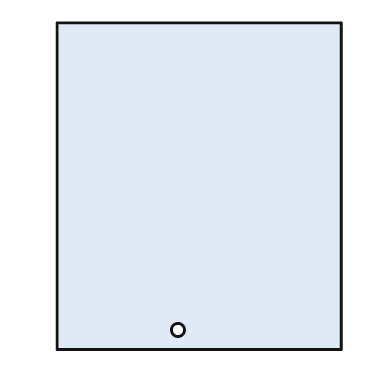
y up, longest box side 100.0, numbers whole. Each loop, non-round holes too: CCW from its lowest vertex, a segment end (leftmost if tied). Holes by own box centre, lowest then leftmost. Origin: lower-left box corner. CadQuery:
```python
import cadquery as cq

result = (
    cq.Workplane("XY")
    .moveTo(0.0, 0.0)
    .lineTo(87.0, 0.0)
    .lineTo(87.0, 100.0)
    .lineTo(0.0, 100.0)
    .close()
    .moveTo(37.0, 6.0)
    .circle(2.0)
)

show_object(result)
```